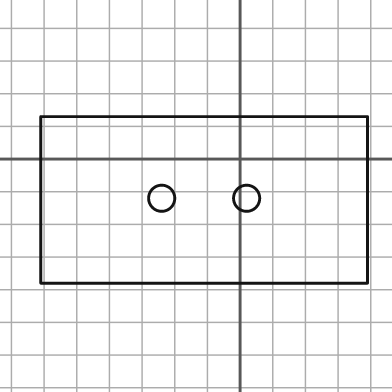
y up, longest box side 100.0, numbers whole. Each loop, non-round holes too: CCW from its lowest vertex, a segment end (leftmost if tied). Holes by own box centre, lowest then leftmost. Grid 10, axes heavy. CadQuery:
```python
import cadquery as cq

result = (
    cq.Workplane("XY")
    .moveTo(-61.0, -38.0)
    .lineTo(39.0, -38.0)
    .lineTo(39.0, 13.0)
    .lineTo(-61.0, 13.0)
    .close()
    .moveTo(-24.0, -12.0)
    .circle(4.0)
    .moveTo(2.0, -12.0)
    .circle(4.0)
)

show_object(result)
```